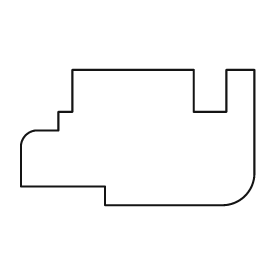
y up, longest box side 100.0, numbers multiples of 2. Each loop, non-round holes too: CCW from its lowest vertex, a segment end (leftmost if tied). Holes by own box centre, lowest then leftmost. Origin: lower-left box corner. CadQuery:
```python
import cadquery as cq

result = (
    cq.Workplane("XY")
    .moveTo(36.0, 0.0)
    .lineTo(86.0, 0.0)
    .threePointArc((96.0, 4.0), (100.0, 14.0))
    .lineTo(100.0, 58.0)
    .lineTo(88.0, 58.0)
    .lineTo(88.0, 40.0)
    .lineTo(74.0, 40.0)
    .lineTo(74.0, 58.0)
    .lineTo(22.0, 58.0)
    .lineTo(22.0, 40.0)
    .lineTo(16.0, 40.0)
    .lineTo(16.0, 32.0)
    .lineTo(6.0, 32.0)
    .threePointArc((2.0, 30.0), (0.0, 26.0))
    .lineTo(0.0, 8.0)
    .lineTo(36.0, 8.0)
    .close()
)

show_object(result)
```